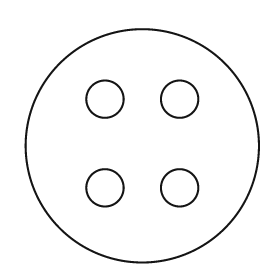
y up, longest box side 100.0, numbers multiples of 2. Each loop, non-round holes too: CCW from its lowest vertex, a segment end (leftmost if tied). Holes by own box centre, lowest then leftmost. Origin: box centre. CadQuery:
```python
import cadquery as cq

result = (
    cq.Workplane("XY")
    .moveTo(0.0, 0.0)
    .circle(50.0)
    .moveTo(-16.0, -18.0)
    .circle(8.0)
    .moveTo(16.0, -18.0)
    .circle(8.0)
    .moveTo(-16.0, 20.0)
    .circle(8.0)
    .moveTo(16.0, 20.0)
    .circle(8.0)
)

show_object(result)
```